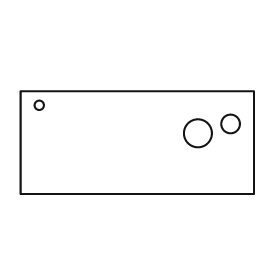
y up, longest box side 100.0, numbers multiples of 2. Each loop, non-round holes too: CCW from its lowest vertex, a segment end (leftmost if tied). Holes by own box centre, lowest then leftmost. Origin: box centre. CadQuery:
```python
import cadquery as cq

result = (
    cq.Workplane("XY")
    .moveTo(-50.0, -22.0)
    .lineTo(50.0, -22.0)
    .lineTo(50.0, 22.0)
    .lineTo(-50.0, 22.0)
    .close()
    .moveTo(26.0, 4.0)
    .circle(6.0)
    .moveTo(40.0, 8.0)
    .circle(4.0)
    .moveTo(-42.0, 16.0)
    .circle(2.0)
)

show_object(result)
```